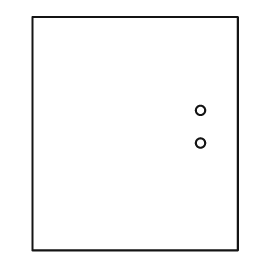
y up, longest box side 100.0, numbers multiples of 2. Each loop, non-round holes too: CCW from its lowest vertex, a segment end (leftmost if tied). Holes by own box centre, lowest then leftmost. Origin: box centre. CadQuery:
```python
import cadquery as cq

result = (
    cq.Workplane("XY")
    .moveTo(-44.0, -50.0)
    .lineTo(44.0, -50.0)
    .lineTo(44.0, 50.0)
    .lineTo(-44.0, 50.0)
    .close()
    .moveTo(28.0, -4.0)
    .circle(2.0)
    .moveTo(28.0, 10.0)
    .circle(2.0)
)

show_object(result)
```